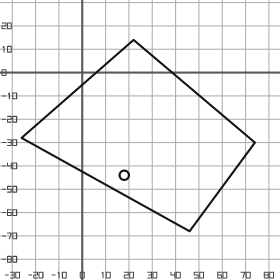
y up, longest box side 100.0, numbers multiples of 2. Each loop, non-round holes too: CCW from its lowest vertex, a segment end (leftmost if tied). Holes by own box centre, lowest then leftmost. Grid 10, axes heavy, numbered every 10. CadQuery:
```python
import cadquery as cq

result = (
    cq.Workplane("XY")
    .moveTo(46.0, -68.0)
    .lineTo(74.0, -30.0)
    .lineTo(22.0, 14.0)
    .lineTo(-26.0, -28.0)
    .close()
    .moveTo(18.0, -44.0)
    .circle(2.0)
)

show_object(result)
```